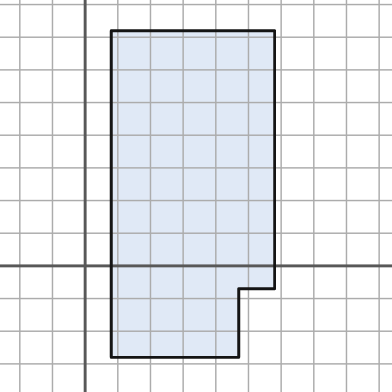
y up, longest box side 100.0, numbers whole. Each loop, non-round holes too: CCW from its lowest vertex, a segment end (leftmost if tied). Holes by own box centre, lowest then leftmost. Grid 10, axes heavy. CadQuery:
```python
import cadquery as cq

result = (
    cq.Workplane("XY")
    .moveTo(8.0, -28.0)
    .lineTo(47.0, -28.0)
    .lineTo(47.0, -7.0)
    .lineTo(58.0, -7.0)
    .lineTo(58.0, 72.0)
    .lineTo(8.0, 72.0)
    .close()
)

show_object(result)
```